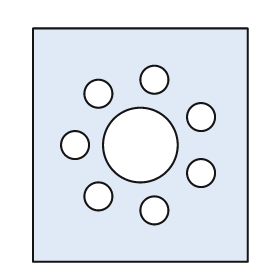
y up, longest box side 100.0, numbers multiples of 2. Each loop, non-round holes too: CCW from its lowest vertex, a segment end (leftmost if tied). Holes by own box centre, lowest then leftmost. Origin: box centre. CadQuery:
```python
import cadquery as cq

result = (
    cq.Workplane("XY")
    .moveTo(-46.0, -50.0)
    .lineTo(46.0, -50.0)
    .lineTo(46.0, 50.0)
    .lineTo(-46.0, 50.0)
    .close()
    .moveTo(6.0, -28.0)
    .circle(6.0)
    .moveTo(-18.0, -22.0)
    .circle(6.0)
    .moveTo(26.0, -12.0)
    .circle(6.0)
    .moveTo(-28.0, 0.0)
    .circle(6.0)
    .moveTo(0.0, 0.0)
    .circle(16.0)
    .moveTo(26.0, 12.0)
    .circle(6.0)
    .moveTo(-18.0, 22.0)
    .circle(6.0)
    .moveTo(6.0, 28.0)
    .circle(6.0)
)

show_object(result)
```